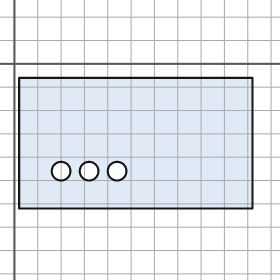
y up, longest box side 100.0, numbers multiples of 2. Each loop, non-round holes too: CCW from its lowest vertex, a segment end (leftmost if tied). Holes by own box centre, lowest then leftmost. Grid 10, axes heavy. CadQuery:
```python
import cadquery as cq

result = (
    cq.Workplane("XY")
    .moveTo(2.0, -62.0)
    .lineTo(102.0, -62.0)
    .lineTo(102.0, -6.0)
    .lineTo(2.0, -6.0)
    .close()
    .moveTo(20.0, -46.0)
    .circle(4.0)
    .moveTo(32.0, -46.0)
    .circle(4.0)
    .moveTo(44.0, -46.0)
    .circle(4.0)
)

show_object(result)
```